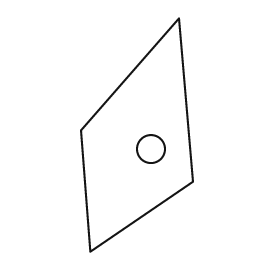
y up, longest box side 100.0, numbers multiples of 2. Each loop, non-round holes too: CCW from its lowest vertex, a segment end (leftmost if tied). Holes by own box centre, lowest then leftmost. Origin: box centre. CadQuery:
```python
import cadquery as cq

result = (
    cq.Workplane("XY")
    .moveTo(-20.0, -50.0)
    .lineTo(24.0, -20.0)
    .lineTo(18.0, 50.0)
    .lineTo(-24.0, 2.0)
    .close()
    .moveTo(6.0, -6.0)
    .circle(6.0)
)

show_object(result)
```